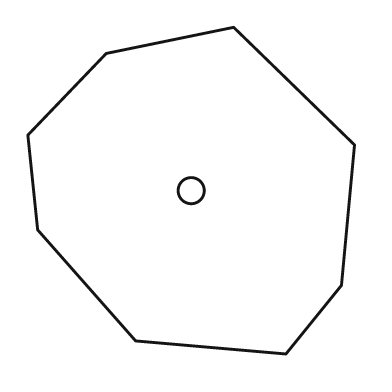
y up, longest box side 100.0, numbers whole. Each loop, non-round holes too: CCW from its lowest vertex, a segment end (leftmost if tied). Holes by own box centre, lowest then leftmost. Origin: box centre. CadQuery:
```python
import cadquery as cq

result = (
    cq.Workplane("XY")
    .moveTo(29.0, -50.0)
    .lineTo(46.0, -29.0)
    .lineTo(50.0, 14.0)
    .lineTo(13.0, 50.0)
    .lineTo(-26.0, 42.0)
    .lineTo(-50.0, 17.0)
    .lineTo(-47.0, -12.0)
    .lineTo(-17.0, -46.0)
    .close()
    .moveTo(0.0, 0.0)
    .circle(4.0)
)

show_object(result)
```